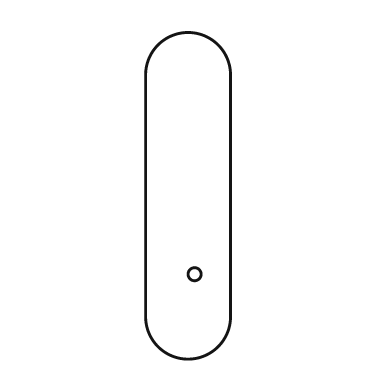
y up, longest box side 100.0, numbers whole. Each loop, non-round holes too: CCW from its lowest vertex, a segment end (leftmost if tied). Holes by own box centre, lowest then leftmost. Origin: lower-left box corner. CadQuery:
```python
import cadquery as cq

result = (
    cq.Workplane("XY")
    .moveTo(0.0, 13.0)
    .threePointArc((13.0, 0.0), (26.0, 13.0))
    .lineTo(26.0, 87.0)
    .threePointArc((13.0, 100.0), (0.0, 87.0))
    .close()
    .moveTo(15.0, 26.0)
    .circle(2.0)
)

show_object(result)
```